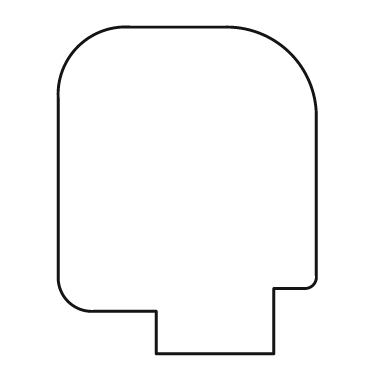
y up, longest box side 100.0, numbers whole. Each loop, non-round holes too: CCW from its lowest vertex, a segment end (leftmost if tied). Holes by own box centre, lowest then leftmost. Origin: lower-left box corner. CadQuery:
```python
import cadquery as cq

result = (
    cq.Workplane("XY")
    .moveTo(30.0, 0.0)
    .lineTo(66.0, 0.0)
    .lineTo(66.0, 20.0)
    .lineTo(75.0, 20.0)
    .threePointArc((78.0, 21.0), (79.0, 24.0))
    .lineTo(79.0, 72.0)
    .threePointArc((71.0, 92.0), (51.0, 100.0))
    .lineTo(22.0, 100.0)
    .threePointArc((6.0, 94.0), (0.0, 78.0))
    .lineTo(0.0, 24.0)
    .threePointArc((3.0, 16.0), (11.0, 13.0))
    .lineTo(30.0, 13.0)
    .close()
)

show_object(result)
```